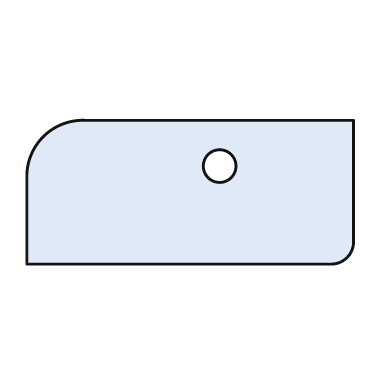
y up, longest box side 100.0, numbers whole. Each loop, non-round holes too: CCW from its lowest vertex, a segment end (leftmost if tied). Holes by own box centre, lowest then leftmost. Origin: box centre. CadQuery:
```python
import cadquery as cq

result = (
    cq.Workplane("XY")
    .moveTo(-50.0, -22.0)
    .lineTo(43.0, -22.0)
    .threePointArc((48.0, -20.0), (50.0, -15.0))
    .lineTo(50.0, 22.0)
    .lineTo(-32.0, 22.0)
    .threePointArc((-45.0, 17.0), (-50.0, 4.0))
    .close()
    .moveTo(9.0, 8.0)
    .circle(5.0)
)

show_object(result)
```